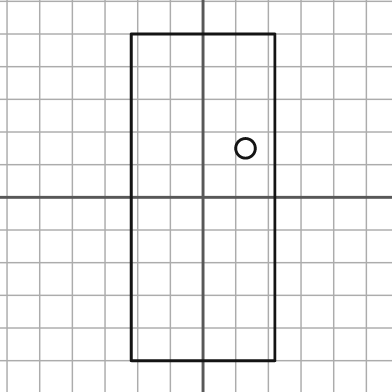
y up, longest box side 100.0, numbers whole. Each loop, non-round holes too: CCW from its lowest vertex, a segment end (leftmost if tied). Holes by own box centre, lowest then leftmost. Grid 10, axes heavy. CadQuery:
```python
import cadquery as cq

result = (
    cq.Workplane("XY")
    .moveTo(-22.0, -50.0)
    .lineTo(22.0, -50.0)
    .lineTo(22.0, 50.0)
    .lineTo(-22.0, 50.0)
    .close()
    .moveTo(13.0, 15.0)
    .circle(3.0)
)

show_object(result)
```